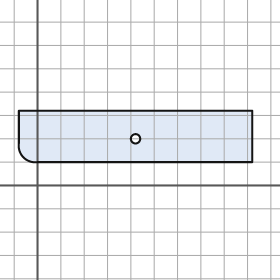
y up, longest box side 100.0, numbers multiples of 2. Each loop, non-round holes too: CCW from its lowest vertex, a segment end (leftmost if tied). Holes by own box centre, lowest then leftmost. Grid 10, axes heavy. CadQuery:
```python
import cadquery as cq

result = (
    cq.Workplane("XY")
    .moveTo(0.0, 10.0)
    .lineTo(92.0, 10.0)
    .lineTo(92.0, 32.0)
    .lineTo(-8.0, 32.0)
    .lineTo(-8.0, 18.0)
    .threePointArc((-6.0, 12.0), (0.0, 10.0))
    .close()
    .moveTo(42.0, 20.0)
    .circle(2.0)
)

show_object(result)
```